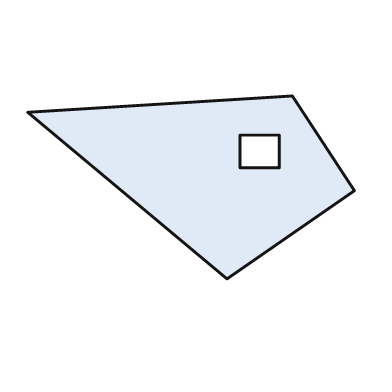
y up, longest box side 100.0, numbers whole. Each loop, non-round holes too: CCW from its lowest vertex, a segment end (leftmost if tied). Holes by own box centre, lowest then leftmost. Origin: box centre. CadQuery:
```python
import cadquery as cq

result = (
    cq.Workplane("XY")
    .moveTo(11.0, -28.0)
    .lineTo(50.0, -1.0)
    .lineTo(31.0, 28.0)
    .lineTo(-50.0, 23.0)
    .close()
    .moveTo(15.0, 6.0)
    .lineTo(27.0, 6.0)
    .lineTo(27.0, 16.0)
    .lineTo(15.0, 16.0)
    .close()
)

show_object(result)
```